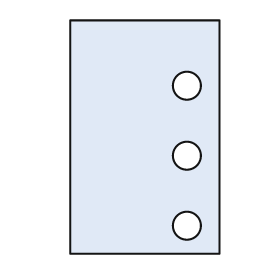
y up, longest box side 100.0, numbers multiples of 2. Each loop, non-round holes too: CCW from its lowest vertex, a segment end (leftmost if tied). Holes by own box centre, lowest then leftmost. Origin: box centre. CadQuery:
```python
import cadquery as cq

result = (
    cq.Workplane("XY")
    .moveTo(-32.0, -50.0)
    .lineTo(32.0, -50.0)
    .lineTo(32.0, 50.0)
    .lineTo(-32.0, 50.0)
    .close()
    .moveTo(18.0, -38.0)
    .circle(6.0)
    .moveTo(18.0, -8.0)
    .circle(6.0)
    .moveTo(18.0, 22.0)
    .circle(6.0)
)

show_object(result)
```